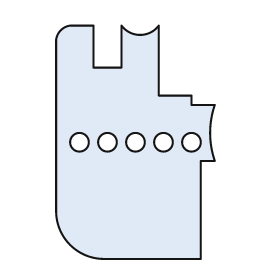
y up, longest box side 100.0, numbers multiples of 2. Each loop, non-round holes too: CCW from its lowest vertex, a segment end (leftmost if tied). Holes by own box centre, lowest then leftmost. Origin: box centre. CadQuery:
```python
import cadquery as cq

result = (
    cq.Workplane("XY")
    .moveTo(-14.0, -50.0)
    .lineTo(28.0, -50.0)
    .lineTo(28.0, -8.0)
    .lineTo(34.0, -8.0)
    .threePointArc((32.0, 4.0), (34.0, 16.0))
    .lineTo(24.0, 16.0)
    .lineTo(24.0, 20.0)
    .lineTo(10.0, 20.0)
    .lineTo(10.0, 50.0)
    .threePointArc((2.0, 46.0), (-6.0, 50.0))
    .lineTo(-6.0, 32.0)
    .lineTo(-18.0, 32.0)
    .lineTo(-18.0, 50.0)
    .lineTo(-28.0, 50.0)
    .threePointArc((-32.0, 48.0), (-34.0, 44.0))
    .lineTo(-34.0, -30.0)
    .threePointArc((-28.0, -44.0), (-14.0, -50.0))
    .close()
    .moveTo(-24.0, 0.0)
    .circle(4.0)
    .moveTo(-12.0, 0.0)
    .circle(4.0)
    .moveTo(0.0, 0.0)
    .circle(4.0)
    .moveTo(12.0, 0.0)
    .circle(4.0)
    .moveTo(24.0, 0.0)
    .circle(4.0)
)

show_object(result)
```